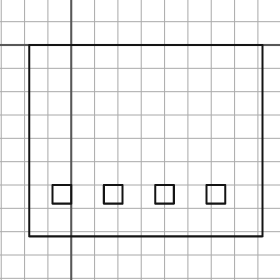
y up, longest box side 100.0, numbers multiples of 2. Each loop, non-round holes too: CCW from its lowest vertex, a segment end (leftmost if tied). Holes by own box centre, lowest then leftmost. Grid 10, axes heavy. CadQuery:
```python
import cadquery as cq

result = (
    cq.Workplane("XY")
    .moveTo(-18.0, -82.0)
    .lineTo(82.0, -82.0)
    .lineTo(82.0, 0.0)
    .lineTo(-18.0, 0.0)
    .close()
    .moveTo(-8.0, -68.0)
    .lineTo(0.0, -68.0)
    .lineTo(0.0, -60.0)
    .lineTo(-8.0, -60.0)
    .close()
    .moveTo(14.0, -68.0)
    .lineTo(22.0, -68.0)
    .lineTo(22.0, -60.0)
    .lineTo(14.0, -60.0)
    .close()
    .moveTo(36.0, -68.0)
    .lineTo(44.0, -68.0)
    .lineTo(44.0, -60.0)
    .lineTo(36.0, -60.0)
    .close()
    .moveTo(58.0, -68.0)
    .lineTo(66.0, -68.0)
    .lineTo(66.0, -60.0)
    .lineTo(58.0, -60.0)
    .close()
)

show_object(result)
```